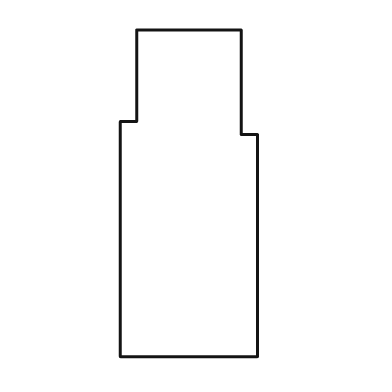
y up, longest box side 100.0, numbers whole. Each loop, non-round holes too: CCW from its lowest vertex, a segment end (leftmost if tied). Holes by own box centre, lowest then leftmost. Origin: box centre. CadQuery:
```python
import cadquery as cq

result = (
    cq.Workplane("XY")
    .moveTo(-21.0, -50.0)
    .lineTo(21.0, -50.0)
    .lineTo(21.0, 18.0)
    .lineTo(16.0, 18.0)
    .lineTo(16.0, 50.0)
    .lineTo(-16.0, 50.0)
    .lineTo(-16.0, 22.0)
    .lineTo(-21.0, 22.0)
    .close()
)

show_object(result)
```